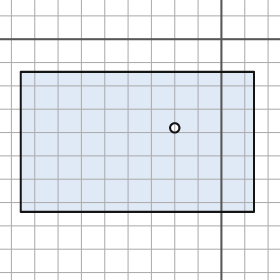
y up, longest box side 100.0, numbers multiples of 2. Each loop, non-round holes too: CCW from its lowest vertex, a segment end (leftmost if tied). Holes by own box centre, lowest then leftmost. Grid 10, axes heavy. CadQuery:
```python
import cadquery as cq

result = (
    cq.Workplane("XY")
    .moveTo(-86.0, -74.0)
    .lineTo(14.0, -74.0)
    .lineTo(14.0, -14.0)
    .lineTo(-86.0, -14.0)
    .close()
    .moveTo(-20.0, -38.0)
    .circle(2.0)
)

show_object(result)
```